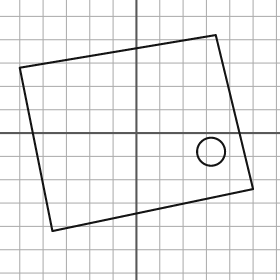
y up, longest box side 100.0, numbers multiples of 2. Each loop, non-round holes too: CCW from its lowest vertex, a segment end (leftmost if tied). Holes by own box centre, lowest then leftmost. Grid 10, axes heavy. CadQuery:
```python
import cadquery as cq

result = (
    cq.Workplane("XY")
    .moveTo(-36.0, -42.0)
    .lineTo(50.0, -24.0)
    .lineTo(34.0, 42.0)
    .lineTo(-50.0, 28.0)
    .close()
    .moveTo(32.0, -8.0)
    .circle(6.0)
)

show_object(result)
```